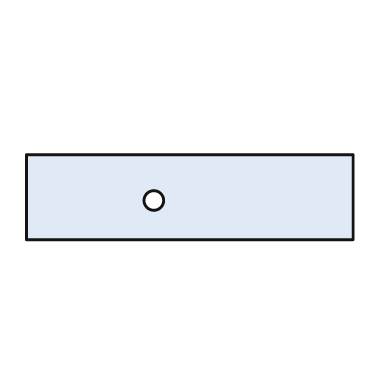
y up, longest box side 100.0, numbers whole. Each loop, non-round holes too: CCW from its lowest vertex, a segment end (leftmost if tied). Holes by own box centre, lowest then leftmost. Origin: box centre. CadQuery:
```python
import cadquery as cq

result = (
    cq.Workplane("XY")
    .moveTo(-50.0, -13.0)
    .lineTo(50.0, -13.0)
    .lineTo(50.0, 13.0)
    .lineTo(-50.0, 13.0)
    .close()
    .moveTo(-11.0, -1.0)
    .circle(3.0)
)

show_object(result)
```